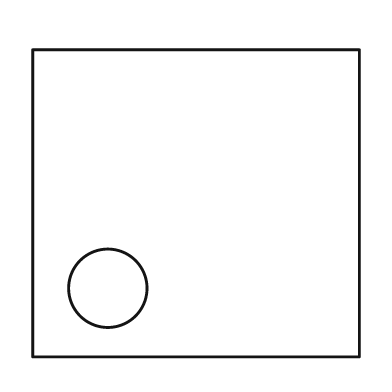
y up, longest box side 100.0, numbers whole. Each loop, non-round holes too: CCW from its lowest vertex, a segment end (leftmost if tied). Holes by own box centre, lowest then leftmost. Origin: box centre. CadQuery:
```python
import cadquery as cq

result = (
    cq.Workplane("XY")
    .moveTo(-50.0, -47.0)
    .lineTo(50.0, -47.0)
    .lineTo(50.0, 47.0)
    .lineTo(-50.0, 47.0)
    .close()
    .moveTo(-27.0, -26.0)
    .circle(12.0)
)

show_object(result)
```